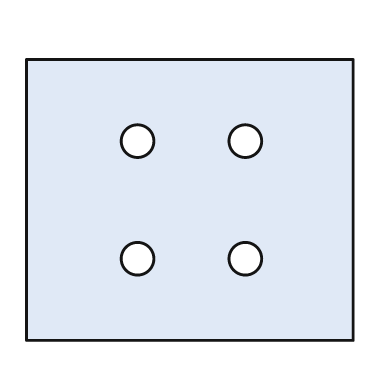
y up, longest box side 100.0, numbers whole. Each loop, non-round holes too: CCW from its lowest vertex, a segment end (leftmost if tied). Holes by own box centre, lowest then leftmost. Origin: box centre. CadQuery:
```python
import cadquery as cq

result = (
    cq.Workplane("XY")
    .moveTo(-50.0, -43.0)
    .lineTo(50.0, -43.0)
    .lineTo(50.0, 43.0)
    .lineTo(-50.0, 43.0)
    .close()
    .moveTo(-16.0, -18.0)
    .circle(5.0)
    .moveTo(17.0, -18.0)
    .circle(5.0)
    .moveTo(-16.0, 18.0)
    .circle(5.0)
    .moveTo(17.0, 18.0)
    .circle(5.0)
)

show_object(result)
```